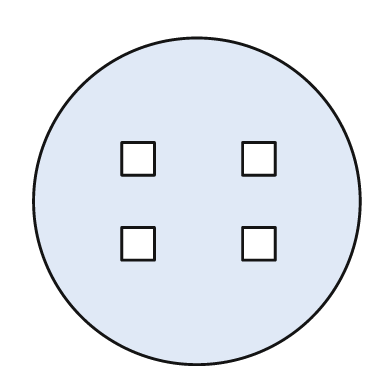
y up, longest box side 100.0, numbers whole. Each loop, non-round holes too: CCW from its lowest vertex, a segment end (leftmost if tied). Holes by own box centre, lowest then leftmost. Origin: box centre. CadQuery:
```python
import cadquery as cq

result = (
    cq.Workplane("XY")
    .moveTo(0.0, 0.0)
    .circle(50.0)
    .moveTo(-23.0, -18.0)
    .lineTo(-13.0, -18.0)
    .lineTo(-13.0, -8.0)
    .lineTo(-23.0, -8.0)
    .close()
    .moveTo(14.0, -18.0)
    .lineTo(24.0, -18.0)
    .lineTo(24.0, -8.0)
    .lineTo(14.0, -8.0)
    .close()
    .moveTo(-23.0, 8.0)
    .lineTo(-13.0, 8.0)
    .lineTo(-13.0, 18.0)
    .lineTo(-23.0, 18.0)
    .close()
    .moveTo(14.0, 8.0)
    .lineTo(24.0, 8.0)
    .lineTo(24.0, 18.0)
    .lineTo(14.0, 18.0)
    .close()
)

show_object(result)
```